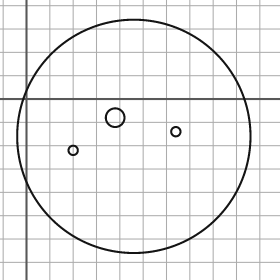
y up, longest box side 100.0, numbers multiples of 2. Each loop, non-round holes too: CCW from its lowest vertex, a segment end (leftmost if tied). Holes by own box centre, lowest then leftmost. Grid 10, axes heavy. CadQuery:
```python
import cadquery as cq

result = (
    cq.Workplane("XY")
    .moveTo(46.0, -16.0)
    .circle(50.0)
    .moveTo(20.0, -22.0)
    .circle(2.0)
    .moveTo(64.0, -14.0)
    .circle(2.0)
    .moveTo(38.0, -8.0)
    .circle(4.0)
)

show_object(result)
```